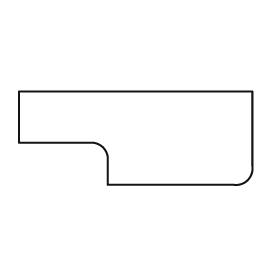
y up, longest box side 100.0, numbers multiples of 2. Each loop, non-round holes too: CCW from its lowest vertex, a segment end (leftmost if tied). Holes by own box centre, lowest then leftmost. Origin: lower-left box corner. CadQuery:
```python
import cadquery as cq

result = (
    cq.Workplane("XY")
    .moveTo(38.0, 0.0)
    .lineTo(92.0, 0.0)
    .threePointArc((98.0, 2.0), (100.0, 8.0))
    .lineTo(100.0, 40.0)
    .lineTo(0.0, 40.0)
    .lineTo(0.0, 18.0)
    .lineTo(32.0, 18.0)
    .threePointArc((36.0, 16.0), (38.0, 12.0))
    .close()
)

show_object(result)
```